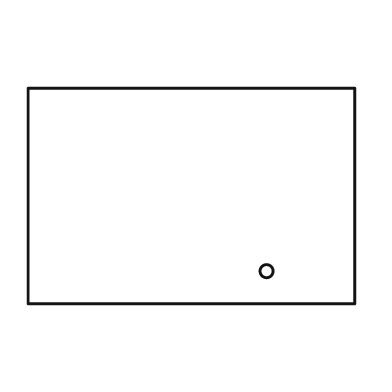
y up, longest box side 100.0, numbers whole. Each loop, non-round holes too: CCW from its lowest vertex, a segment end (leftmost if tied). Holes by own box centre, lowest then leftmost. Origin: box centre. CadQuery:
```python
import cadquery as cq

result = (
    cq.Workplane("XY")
    .moveTo(-50.0, -33.0)
    .lineTo(50.0, -33.0)
    .lineTo(50.0, 33.0)
    .lineTo(-50.0, 33.0)
    .close()
    .moveTo(23.0, -23.0)
    .circle(2.0)
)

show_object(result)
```